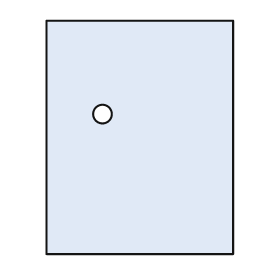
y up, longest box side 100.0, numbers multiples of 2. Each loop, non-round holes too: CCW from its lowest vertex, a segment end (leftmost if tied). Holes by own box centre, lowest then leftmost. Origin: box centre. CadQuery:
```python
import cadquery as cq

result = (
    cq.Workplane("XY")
    .moveTo(-40.0, -50.0)
    .lineTo(40.0, -50.0)
    .lineTo(40.0, 50.0)
    .lineTo(-40.0, 50.0)
    .close()
    .moveTo(-16.0, 10.0)
    .circle(4.0)
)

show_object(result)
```